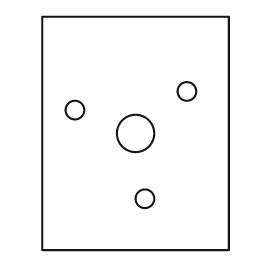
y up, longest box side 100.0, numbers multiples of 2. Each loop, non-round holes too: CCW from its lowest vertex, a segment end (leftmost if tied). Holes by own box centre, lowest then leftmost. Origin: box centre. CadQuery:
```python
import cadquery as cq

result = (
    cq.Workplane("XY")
    .moveTo(-40.0, -50.0)
    .lineTo(40.0, -50.0)
    .lineTo(40.0, 50.0)
    .lineTo(-40.0, 50.0)
    .close()
    .moveTo(4.0, -28.0)
    .circle(4.0)
    .moveTo(0.0, 0.0)
    .circle(8.0)
    .moveTo(-26.0, 10.0)
    .circle(4.0)
    .moveTo(22.0, 18.0)
    .circle(4.0)
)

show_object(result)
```